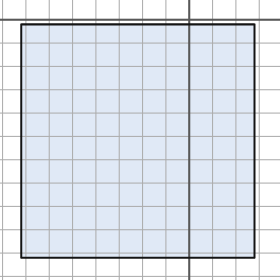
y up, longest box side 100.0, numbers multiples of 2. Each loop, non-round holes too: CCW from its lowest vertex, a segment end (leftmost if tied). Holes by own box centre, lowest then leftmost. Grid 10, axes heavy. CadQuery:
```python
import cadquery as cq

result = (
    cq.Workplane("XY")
    .moveTo(-72.0, -102.0)
    .lineTo(28.0, -102.0)
    .lineTo(28.0, -2.0)
    .lineTo(-72.0, -2.0)
    .close()
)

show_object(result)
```